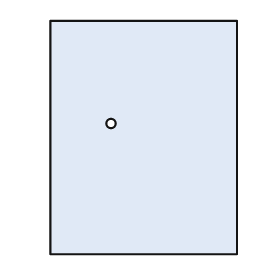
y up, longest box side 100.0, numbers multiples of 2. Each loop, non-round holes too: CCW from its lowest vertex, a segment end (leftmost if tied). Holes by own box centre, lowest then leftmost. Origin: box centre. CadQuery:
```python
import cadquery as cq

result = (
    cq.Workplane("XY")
    .moveTo(-40.0, -50.0)
    .lineTo(40.0, -50.0)
    .lineTo(40.0, 50.0)
    .lineTo(-40.0, 50.0)
    .close()
    .moveTo(-14.0, 6.0)
    .circle(2.0)
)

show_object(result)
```